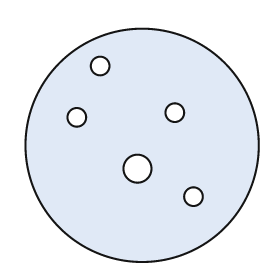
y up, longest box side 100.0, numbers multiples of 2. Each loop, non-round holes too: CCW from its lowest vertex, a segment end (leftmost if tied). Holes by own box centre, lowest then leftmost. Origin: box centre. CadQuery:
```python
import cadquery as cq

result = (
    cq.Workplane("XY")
    .moveTo(0.0, 0.0)
    .circle(50.0)
    .moveTo(22.0, -22.0)
    .circle(4.0)
    .moveTo(-2.0, -10.0)
    .circle(6.0)
    .moveTo(-28.0, 12.0)
    .circle(4.0)
    .moveTo(14.0, 14.0)
    .circle(4.0)
    .moveTo(-18.0, 34.0)
    .circle(4.0)
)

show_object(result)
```